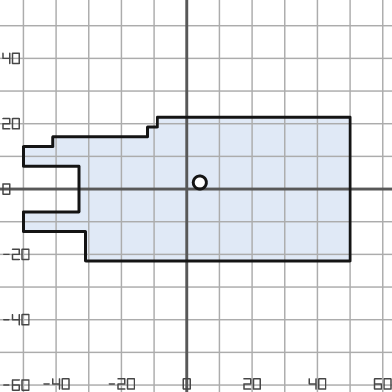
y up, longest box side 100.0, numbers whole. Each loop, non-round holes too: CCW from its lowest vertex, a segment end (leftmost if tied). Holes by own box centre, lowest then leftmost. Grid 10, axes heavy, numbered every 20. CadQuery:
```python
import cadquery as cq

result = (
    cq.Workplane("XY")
    .moveTo(-31.0, -22.0)
    .lineTo(50.0, -22.0)
    .lineTo(50.0, 22.0)
    .lineTo(-9.0, 22.0)
    .lineTo(-9.0, 19.0)
    .lineTo(-12.0, 19.0)
    .lineTo(-12.0, 16.0)
    .lineTo(-41.0, 16.0)
    .lineTo(-41.0, 13.0)
    .lineTo(-50.0, 13.0)
    .lineTo(-50.0, 7.0)
    .lineTo(-33.0, 7.0)
    .lineTo(-33.0, -7.0)
    .lineTo(-50.0, -7.0)
    .lineTo(-50.0, -13.0)
    .lineTo(-31.0, -13.0)
    .close()
    .moveTo(4.0, 2.0)
    .circle(2.0)
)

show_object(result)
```